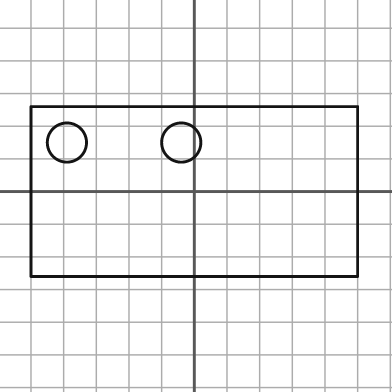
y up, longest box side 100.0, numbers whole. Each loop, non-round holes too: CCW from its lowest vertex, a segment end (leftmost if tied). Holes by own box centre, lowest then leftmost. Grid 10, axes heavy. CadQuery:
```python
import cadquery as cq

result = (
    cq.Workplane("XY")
    .moveTo(-50.0, -26.0)
    .lineTo(50.0, -26.0)
    .lineTo(50.0, 26.0)
    .lineTo(-50.0, 26.0)
    .close()
    .moveTo(-39.0, 15.0)
    .circle(6.0)
    .moveTo(-4.0, 15.0)
    .circle(6.0)
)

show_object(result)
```